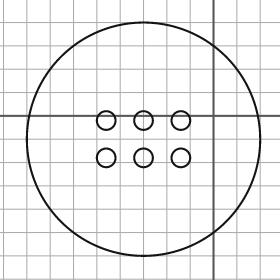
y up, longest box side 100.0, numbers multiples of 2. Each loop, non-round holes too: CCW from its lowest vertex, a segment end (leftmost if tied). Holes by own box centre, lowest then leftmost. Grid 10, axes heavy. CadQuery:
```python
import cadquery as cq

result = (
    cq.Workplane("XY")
    .moveTo(-30.0, -10.0)
    .circle(50.0)
    .moveTo(-46.0, -18.0)
    .circle(4.0)
    .moveTo(-30.0, -18.0)
    .circle(4.0)
    .moveTo(-14.0, -18.0)
    .circle(4.0)
    .moveTo(-46.0, -2.0)
    .circle(4.0)
    .moveTo(-30.0, -2.0)
    .circle(4.0)
    .moveTo(-14.0, -2.0)
    .circle(4.0)
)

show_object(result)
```